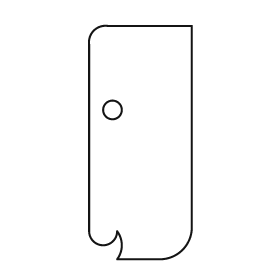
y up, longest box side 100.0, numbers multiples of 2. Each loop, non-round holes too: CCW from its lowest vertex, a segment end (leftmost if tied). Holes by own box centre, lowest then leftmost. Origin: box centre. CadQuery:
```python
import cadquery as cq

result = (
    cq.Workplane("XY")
    .moveTo(-10.0, -50.0)
    .lineTo(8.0, -50.0)
    .threePointArc((18.0, -46.0), (22.0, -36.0))
    .lineTo(22.0, 50.0)
    .lineTo(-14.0, 50.0)
    .threePointArc((-20.0, 48.0), (-22.0, 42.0))
    .lineTo(-22.0, -38.0)
    .threePointArc((-16.0, -44.0), (-10.0, -38.0))
    .threePointArc((-8.0, -44.0), (-10.0, -50.0))
    .close()
    .moveTo(-12.0, 14.0)
    .circle(4.0)
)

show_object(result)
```